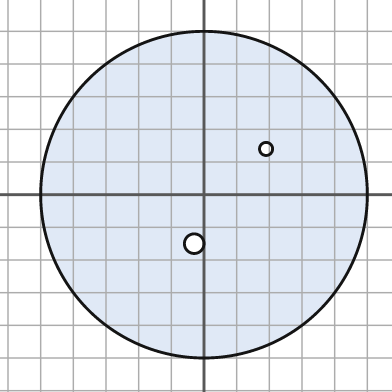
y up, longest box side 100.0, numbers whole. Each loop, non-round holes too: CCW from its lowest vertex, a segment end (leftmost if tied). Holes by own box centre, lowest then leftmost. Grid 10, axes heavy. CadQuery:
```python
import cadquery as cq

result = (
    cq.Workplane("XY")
    .moveTo(0.0, 0.0)
    .circle(50.0)
    .moveTo(-3.0, -15.0)
    .circle(3.0)
    .moveTo(19.0, 14.0)
    .circle(2.0)
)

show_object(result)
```